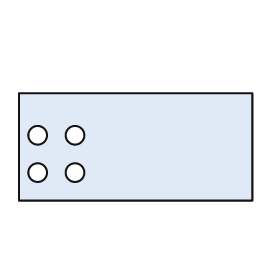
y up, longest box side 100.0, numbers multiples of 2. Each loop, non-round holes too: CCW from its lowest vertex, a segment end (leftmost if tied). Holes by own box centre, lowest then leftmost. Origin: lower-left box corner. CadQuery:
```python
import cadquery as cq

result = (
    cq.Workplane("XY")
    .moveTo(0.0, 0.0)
    .lineTo(100.0, 0.0)
    .lineTo(100.0, 46.0)
    .lineTo(0.0, 46.0)
    .close()
    .moveTo(8.0, 12.0)
    .circle(4.0)
    .moveTo(24.0, 12.0)
    .circle(4.0)
    .moveTo(8.0, 28.0)
    .circle(4.0)
    .moveTo(24.0, 28.0)
    .circle(4.0)
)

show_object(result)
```